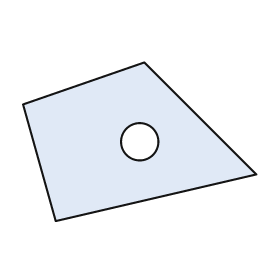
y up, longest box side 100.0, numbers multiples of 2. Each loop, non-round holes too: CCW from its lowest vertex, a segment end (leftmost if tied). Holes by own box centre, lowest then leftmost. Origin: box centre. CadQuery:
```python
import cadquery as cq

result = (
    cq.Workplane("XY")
    .moveTo(-36.0, -34.0)
    .lineTo(50.0, -14.0)
    .lineTo(2.0, 34.0)
    .lineTo(-50.0, 16.0)
    .close()
    .moveTo(0.0, 0.0)
    .circle(8.0)
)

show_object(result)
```